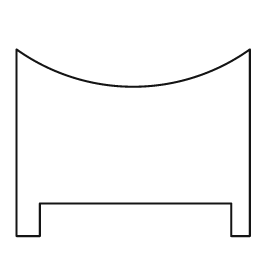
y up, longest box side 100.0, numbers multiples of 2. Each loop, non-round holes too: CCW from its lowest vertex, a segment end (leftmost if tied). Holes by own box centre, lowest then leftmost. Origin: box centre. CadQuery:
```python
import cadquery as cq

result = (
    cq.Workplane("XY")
    .moveTo(-50.0, -40.0)
    .lineTo(-40.0, -40.0)
    .lineTo(-40.0, -26.0)
    .lineTo(42.0, -26.0)
    .lineTo(42.0, -40.0)
    .lineTo(50.0, -40.0)
    .lineTo(50.0, 40.0)
    .threePointArc((0.0, 24.0), (-50.0, 40.0))
    .close()
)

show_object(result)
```